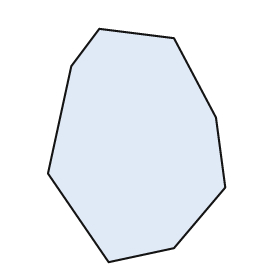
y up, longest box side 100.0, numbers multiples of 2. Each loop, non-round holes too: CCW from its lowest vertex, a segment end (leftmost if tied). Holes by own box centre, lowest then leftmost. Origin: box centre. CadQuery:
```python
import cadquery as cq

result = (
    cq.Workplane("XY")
    .moveTo(-12.0, -50.0)
    .lineTo(16.0, -44.0)
    .lineTo(38.0, -18.0)
    .lineTo(34.0, 12.0)
    .lineTo(16.0, 46.0)
    .lineTo(-16.0, 50.0)
    .lineTo(-28.0, 34.0)
    .lineTo(-38.0, -12.0)
    .close()
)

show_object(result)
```